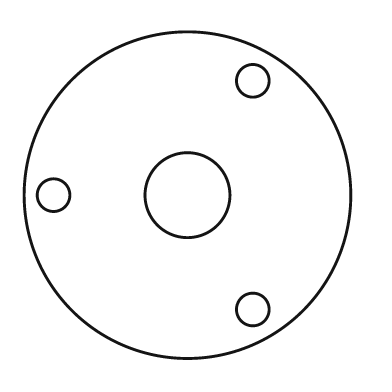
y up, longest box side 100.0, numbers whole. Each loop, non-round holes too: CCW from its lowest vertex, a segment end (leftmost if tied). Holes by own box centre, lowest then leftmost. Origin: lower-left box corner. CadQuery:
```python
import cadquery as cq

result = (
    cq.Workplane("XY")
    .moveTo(50.0, 50.0)
    .circle(50.0)
    .moveTo(70.0, 15.0)
    .circle(5.0)
    .moveTo(9.0, 50.0)
    .circle(5.0)
    .moveTo(50.0, 50.0)
    .circle(13.0)
    .moveTo(70.0, 85.0)
    .circle(5.0)
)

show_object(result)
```